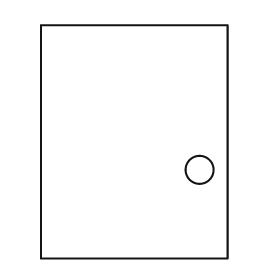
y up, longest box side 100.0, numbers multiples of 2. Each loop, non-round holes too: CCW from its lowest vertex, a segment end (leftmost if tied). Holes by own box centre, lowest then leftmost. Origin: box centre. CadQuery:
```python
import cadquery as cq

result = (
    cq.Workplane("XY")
    .moveTo(-40.0, -50.0)
    .lineTo(40.0, -50.0)
    .lineTo(40.0, 50.0)
    .lineTo(-40.0, 50.0)
    .close()
    .moveTo(28.0, -12.0)
    .circle(6.0)
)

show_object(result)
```